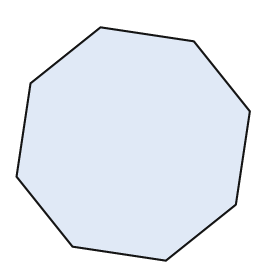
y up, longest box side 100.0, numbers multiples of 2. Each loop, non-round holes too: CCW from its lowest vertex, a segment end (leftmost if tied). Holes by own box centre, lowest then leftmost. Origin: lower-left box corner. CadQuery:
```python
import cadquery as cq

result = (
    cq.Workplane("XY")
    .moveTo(64.0, 0.0)
    .lineTo(94.0, 24.0)
    .lineTo(100.0, 64.0)
    .lineTo(76.0, 94.0)
    .lineTo(36.0, 100.0)
    .lineTo(6.0, 76.0)
    .lineTo(0.0, 36.0)
    .lineTo(24.0, 6.0)
    .close()
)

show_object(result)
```